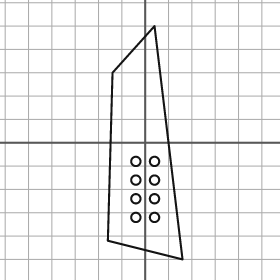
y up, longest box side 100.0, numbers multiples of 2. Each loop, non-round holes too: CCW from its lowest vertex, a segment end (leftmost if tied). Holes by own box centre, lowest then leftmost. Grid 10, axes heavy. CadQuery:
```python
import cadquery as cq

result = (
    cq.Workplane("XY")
    .moveTo(16.0, -50.0)
    .lineTo(4.0, 50.0)
    .lineTo(-14.0, 30.0)
    .lineTo(-16.0, -42.0)
    .close()
    .moveTo(-4.0, -32.0)
    .circle(2.0)
    .moveTo(4.0, -32.0)
    .circle(2.0)
    .moveTo(-4.0, -24.0)
    .circle(2.0)
    .moveTo(4.0, -24.0)
    .circle(2.0)
    .moveTo(-4.0, -16.0)
    .circle(2.0)
    .moveTo(4.0, -16.0)
    .circle(2.0)
    .moveTo(-4.0, -8.0)
    .circle(2.0)
    .moveTo(4.0, -8.0)
    .circle(2.0)
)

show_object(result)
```